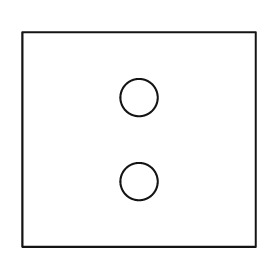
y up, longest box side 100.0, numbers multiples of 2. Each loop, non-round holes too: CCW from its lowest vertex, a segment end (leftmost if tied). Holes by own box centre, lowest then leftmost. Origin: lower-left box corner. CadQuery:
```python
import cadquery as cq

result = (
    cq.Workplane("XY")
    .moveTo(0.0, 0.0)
    .lineTo(100.0, 0.0)
    .lineTo(100.0, 92.0)
    .lineTo(0.0, 92.0)
    .close()
    .moveTo(50.0, 28.0)
    .circle(8.0)
    .moveTo(50.0, 64.0)
    .circle(8.0)
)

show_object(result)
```